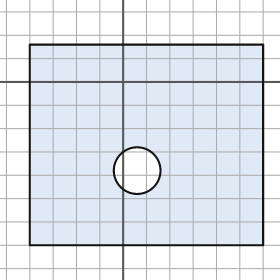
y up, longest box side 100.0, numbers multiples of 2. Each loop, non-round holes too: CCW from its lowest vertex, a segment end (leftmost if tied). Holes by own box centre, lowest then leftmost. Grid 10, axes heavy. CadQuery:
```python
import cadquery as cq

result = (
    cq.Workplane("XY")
    .moveTo(-40.0, -70.0)
    .lineTo(60.0, -70.0)
    .lineTo(60.0, 16.0)
    .lineTo(-40.0, 16.0)
    .close()
    .moveTo(6.0, -38.0)
    .circle(10.0)
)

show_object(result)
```